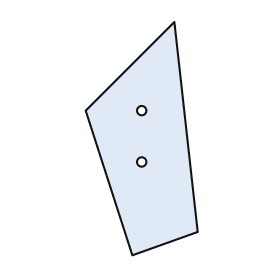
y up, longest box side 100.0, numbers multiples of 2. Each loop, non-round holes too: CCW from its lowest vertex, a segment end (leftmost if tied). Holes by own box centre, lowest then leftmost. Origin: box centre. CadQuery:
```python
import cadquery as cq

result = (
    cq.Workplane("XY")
    .moveTo(-4.0, -50.0)
    .lineTo(24.0, -40.0)
    .lineTo(14.0, 50.0)
    .lineTo(-24.0, 12.0)
    .close()
    .moveTo(0.0, -10.0)
    .circle(2.0)
    .moveTo(0.0, 12.0)
    .circle(2.0)
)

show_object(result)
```